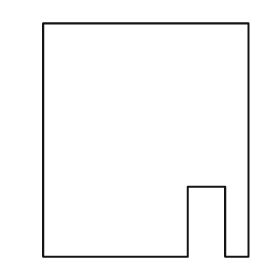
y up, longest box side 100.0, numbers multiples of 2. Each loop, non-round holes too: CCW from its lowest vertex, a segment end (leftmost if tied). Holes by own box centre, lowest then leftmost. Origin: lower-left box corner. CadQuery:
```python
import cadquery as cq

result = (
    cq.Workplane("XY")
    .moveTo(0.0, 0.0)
    .lineTo(62.0, 0.0)
    .lineTo(62.0, 30.0)
    .lineTo(78.0, 30.0)
    .lineTo(78.0, 0.0)
    .lineTo(88.0, 0.0)
    .lineTo(88.0, 100.0)
    .lineTo(0.0, 100.0)
    .close()
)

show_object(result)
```